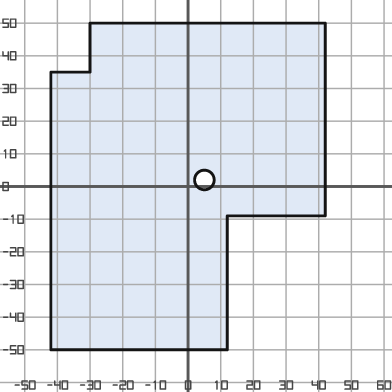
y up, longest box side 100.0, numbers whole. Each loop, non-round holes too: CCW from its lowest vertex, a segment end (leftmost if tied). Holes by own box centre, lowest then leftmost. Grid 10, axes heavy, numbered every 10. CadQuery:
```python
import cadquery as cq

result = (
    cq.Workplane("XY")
    .moveTo(-42.0, -50.0)
    .lineTo(12.0, -50.0)
    .lineTo(12.0, -9.0)
    .lineTo(42.0, -9.0)
    .lineTo(42.0, 50.0)
    .lineTo(-30.0, 50.0)
    .lineTo(-30.0, 35.0)
    .lineTo(-42.0, 35.0)
    .close()
    .moveTo(5.0, 2.0)
    .circle(3.0)
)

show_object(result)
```